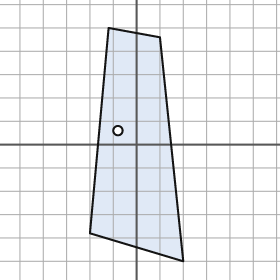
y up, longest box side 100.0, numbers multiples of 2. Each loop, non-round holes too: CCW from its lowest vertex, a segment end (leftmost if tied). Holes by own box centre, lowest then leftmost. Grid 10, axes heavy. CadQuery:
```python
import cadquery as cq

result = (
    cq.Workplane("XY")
    .moveTo(20.0, -50.0)
    .lineTo(10.0, 46.0)
    .lineTo(-12.0, 50.0)
    .lineTo(-20.0, -38.0)
    .close()
    .moveTo(-8.0, 6.0)
    .circle(2.0)
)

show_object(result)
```